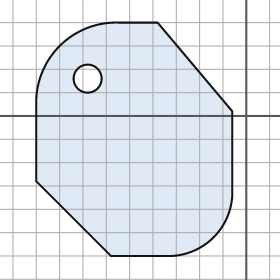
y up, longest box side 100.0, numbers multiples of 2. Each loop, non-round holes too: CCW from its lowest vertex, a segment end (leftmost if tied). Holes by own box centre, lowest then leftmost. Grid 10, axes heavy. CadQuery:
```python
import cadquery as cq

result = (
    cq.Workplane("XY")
    .moveTo(-58.0, -60.0)
    .lineTo(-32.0, -60.0)
    .threePointArc((-14.0, -52.0), (-6.0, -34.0))
    .lineTo(-6.0, 2.0)
    .lineTo(-38.0, 40.0)
    .lineTo(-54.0, 40.0)
    .threePointArc((-80.0, 30.0), (-90.0, 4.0))
    .lineTo(-90.0, -28.0)
    .close()
    .moveTo(-68.0, 16.0)
    .circle(6.0)
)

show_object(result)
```